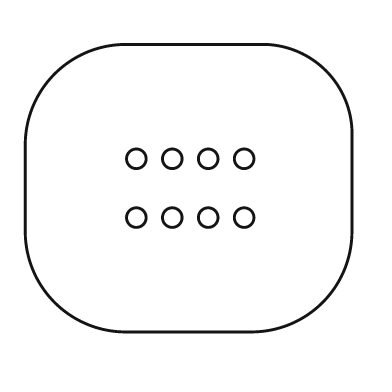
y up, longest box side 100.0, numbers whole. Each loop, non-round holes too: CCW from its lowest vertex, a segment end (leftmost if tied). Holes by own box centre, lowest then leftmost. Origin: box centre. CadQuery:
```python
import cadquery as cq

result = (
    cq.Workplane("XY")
    .moveTo(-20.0, -44.0)
    .lineTo(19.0, -44.0)
    .threePointArc((41.0, -35.0), (50.0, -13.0))
    .lineTo(50.0, 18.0)
    .threePointArc((42.0, 36.0), (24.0, 44.0))
    .lineTo(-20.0, 44.0)
    .threePointArc((-41.0, 35.0), (-50.0, 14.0))
    .lineTo(-50.0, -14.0)
    .threePointArc((-41.0, -35.0), (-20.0, -44.0))
    .close()
    .moveTo(-16.0, -9.0)
    .circle(3.0)
    .moveTo(-5.0, -9.0)
    .circle(3.0)
    .moveTo(6.0, -9.0)
    .circle(3.0)
    .moveTo(17.0, -9.0)
    .circle(3.0)
    .moveTo(-16.0, 9.0)
    .circle(3.0)
    .moveTo(-5.0, 9.0)
    .circle(3.0)
    .moveTo(6.0, 9.0)
    .circle(3.0)
    .moveTo(17.0, 9.0)
    .circle(3.0)
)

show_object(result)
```